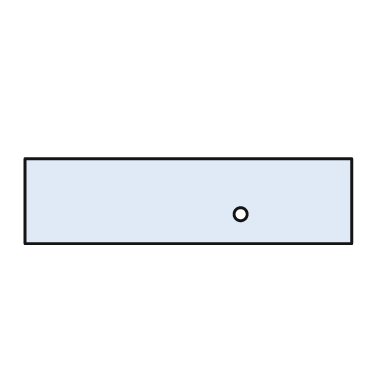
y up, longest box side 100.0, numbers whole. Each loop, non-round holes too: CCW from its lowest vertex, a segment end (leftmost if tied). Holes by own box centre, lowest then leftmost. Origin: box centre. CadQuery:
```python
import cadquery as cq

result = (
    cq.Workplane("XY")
    .moveTo(-50.0, -13.0)
    .lineTo(50.0, -13.0)
    .lineTo(50.0, 13.0)
    .lineTo(-50.0, 13.0)
    .close()
    .moveTo(16.0, -4.0)
    .circle(2.0)
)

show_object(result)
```